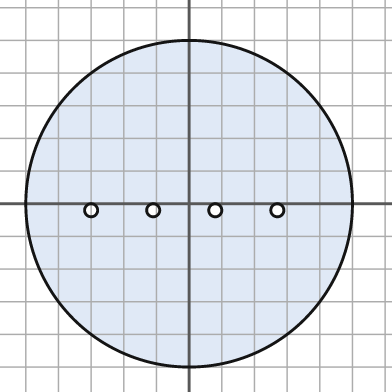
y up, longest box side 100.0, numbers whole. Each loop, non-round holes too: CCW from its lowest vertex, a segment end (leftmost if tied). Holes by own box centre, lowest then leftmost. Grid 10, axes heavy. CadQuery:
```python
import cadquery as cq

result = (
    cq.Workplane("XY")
    .moveTo(0.0, 0.0)
    .circle(50.0)
    .moveTo(-30.0, -2.0)
    .circle(2.0)
    .moveTo(-11.0, -2.0)
    .circle(2.0)
    .moveTo(8.0, -2.0)
    .circle(2.0)
    .moveTo(27.0, -2.0)
    .circle(2.0)
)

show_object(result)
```